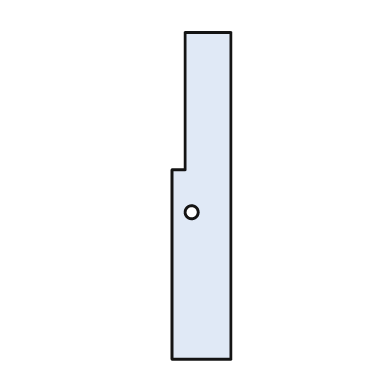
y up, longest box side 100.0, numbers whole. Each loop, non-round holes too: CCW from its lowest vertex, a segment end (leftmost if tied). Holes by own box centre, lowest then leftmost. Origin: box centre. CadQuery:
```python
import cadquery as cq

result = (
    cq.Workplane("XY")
    .moveTo(-9.0, -50.0)
    .lineTo(9.0, -50.0)
    .lineTo(9.0, 50.0)
    .lineTo(-5.0, 50.0)
    .lineTo(-5.0, 8.0)
    .lineTo(-9.0, 8.0)
    .close()
    .moveTo(-3.0, -5.0)
    .circle(2.0)
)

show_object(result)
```